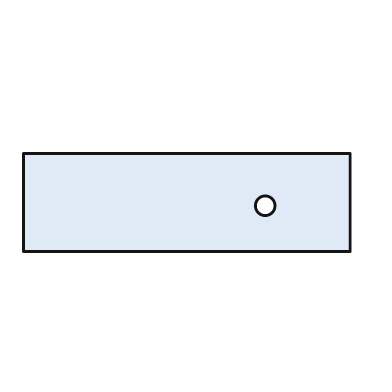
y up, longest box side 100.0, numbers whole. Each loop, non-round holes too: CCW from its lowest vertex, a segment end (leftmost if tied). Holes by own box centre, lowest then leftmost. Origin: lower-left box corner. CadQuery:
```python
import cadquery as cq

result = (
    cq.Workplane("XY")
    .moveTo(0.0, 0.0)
    .lineTo(100.0, 0.0)
    .lineTo(100.0, 30.0)
    .lineTo(0.0, 30.0)
    .close()
    .moveTo(74.0, 14.0)
    .circle(3.0)
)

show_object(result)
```